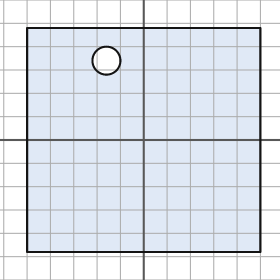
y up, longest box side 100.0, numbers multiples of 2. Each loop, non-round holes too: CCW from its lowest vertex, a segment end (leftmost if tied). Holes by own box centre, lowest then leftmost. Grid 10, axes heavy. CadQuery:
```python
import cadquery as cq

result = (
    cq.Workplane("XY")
    .moveTo(-50.0, -48.0)
    .lineTo(50.0, -48.0)
    .lineTo(50.0, 48.0)
    .lineTo(-50.0, 48.0)
    .close()
    .moveTo(-16.0, 34.0)
    .circle(6.0)
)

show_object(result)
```